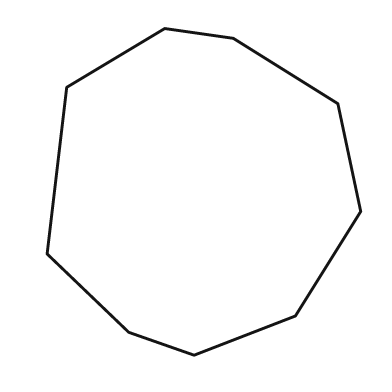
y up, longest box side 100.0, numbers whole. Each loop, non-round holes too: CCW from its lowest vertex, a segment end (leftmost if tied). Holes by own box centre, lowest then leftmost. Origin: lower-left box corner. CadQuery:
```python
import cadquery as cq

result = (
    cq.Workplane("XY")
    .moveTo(45.0, 0.0)
    .lineTo(76.0, 12.0)
    .lineTo(96.0, 44.0)
    .lineTo(89.0, 77.0)
    .lineTo(57.0, 97.0)
    .lineTo(36.0, 100.0)
    .lineTo(6.0, 82.0)
    .lineTo(0.0, 31.0)
    .lineTo(25.0, 7.0)
    .close()
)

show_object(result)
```